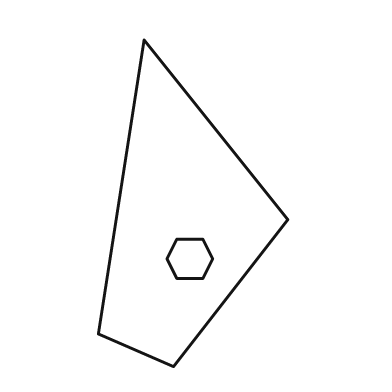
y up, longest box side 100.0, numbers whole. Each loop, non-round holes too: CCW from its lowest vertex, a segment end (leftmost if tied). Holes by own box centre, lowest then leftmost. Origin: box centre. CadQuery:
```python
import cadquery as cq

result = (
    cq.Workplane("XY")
    .moveTo(-6.0, -50.0)
    .lineTo(29.0, -5.0)
    .lineTo(-15.0, 50.0)
    .lineTo(-29.0, -40.0)
    .close()
    .moveTo(-5.0, -23.0)
    .lineTo(3.0, -23.0)
    .lineTo(6.0, -17.0)
    .lineTo(3.0, -11.0)
    .lineTo(-5.0, -11.0)
    .lineTo(-8.0, -17.0)
    .close()
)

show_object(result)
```